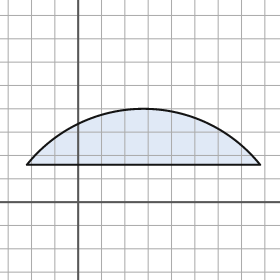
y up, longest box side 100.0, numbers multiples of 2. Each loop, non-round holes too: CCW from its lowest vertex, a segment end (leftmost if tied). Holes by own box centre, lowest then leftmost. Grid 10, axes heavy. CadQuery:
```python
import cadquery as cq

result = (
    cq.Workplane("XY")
    .moveTo(-22.0, 16.0)
    .lineTo(78.0, 16.0)
    .threePointArc((28.0, 40.0), (-22.0, 16.0))
    .close()
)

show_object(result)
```